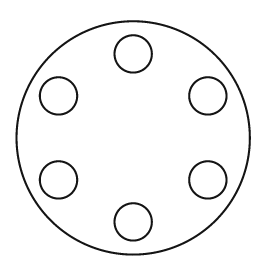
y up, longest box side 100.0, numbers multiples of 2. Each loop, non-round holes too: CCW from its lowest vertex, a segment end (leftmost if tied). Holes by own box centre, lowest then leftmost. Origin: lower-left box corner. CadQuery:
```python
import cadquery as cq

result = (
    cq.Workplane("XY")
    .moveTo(50.0, 50.0)
    .circle(50.0)
    .moveTo(50.0, 14.0)
    .circle(8.0)
    .moveTo(18.0, 32.0)
    .circle(8.0)
    .moveTo(82.0, 32.0)
    .circle(8.0)
    .moveTo(18.0, 68.0)
    .circle(8.0)
    .moveTo(82.0, 68.0)
    .circle(8.0)
    .moveTo(50.0, 86.0)
    .circle(8.0)
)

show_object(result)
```